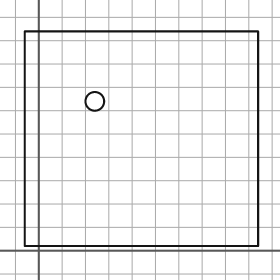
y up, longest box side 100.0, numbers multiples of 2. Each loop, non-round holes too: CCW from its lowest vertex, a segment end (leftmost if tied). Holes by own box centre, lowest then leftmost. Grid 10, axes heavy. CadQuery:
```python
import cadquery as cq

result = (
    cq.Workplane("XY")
    .moveTo(-6.0, 2.0)
    .lineTo(94.0, 2.0)
    .lineTo(94.0, 94.0)
    .lineTo(-6.0, 94.0)
    .close()
    .moveTo(24.0, 64.0)
    .circle(4.0)
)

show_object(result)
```